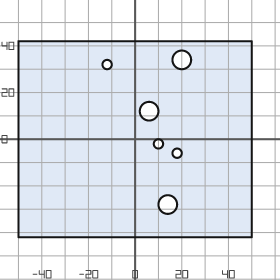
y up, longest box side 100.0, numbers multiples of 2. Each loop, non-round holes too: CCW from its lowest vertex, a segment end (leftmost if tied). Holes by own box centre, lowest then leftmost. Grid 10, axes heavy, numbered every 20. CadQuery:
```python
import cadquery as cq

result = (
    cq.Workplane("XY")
    .moveTo(-50.0, -42.0)
    .lineTo(50.0, -42.0)
    .lineTo(50.0, 42.0)
    .lineTo(-50.0, 42.0)
    .close()
    .moveTo(14.0, -28.0)
    .circle(4.0)
    .moveTo(18.0, -6.0)
    .circle(2.0)
    .moveTo(10.0, -2.0)
    .circle(2.0)
    .moveTo(6.0, 12.0)
    .circle(4.0)
    .moveTo(-12.0, 32.0)
    .circle(2.0)
    .moveTo(20.0, 34.0)
    .circle(4.0)
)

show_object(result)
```